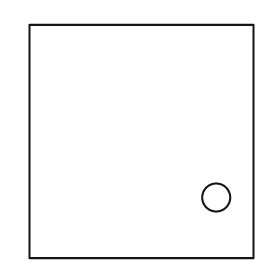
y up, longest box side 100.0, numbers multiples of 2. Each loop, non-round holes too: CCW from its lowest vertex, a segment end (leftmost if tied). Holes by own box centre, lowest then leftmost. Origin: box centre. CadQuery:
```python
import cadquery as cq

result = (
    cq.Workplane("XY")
    .moveTo(-48.0, -50.0)
    .lineTo(48.0, -50.0)
    .lineTo(48.0, 50.0)
    .lineTo(-48.0, 50.0)
    .close()
    .moveTo(32.0, -24.0)
    .circle(6.0)
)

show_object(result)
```